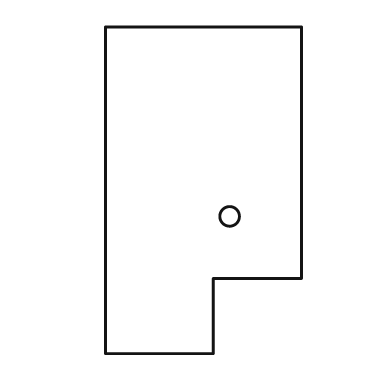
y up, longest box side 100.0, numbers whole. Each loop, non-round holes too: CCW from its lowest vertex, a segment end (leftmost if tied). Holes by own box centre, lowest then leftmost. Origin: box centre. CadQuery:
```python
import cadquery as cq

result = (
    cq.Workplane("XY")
    .moveTo(-30.0, -50.0)
    .lineTo(3.0, -50.0)
    .lineTo(3.0, -27.0)
    .lineTo(30.0, -27.0)
    .lineTo(30.0, 50.0)
    .lineTo(-30.0, 50.0)
    .close()
    .moveTo(8.0, -8.0)
    .circle(3.0)
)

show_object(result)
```